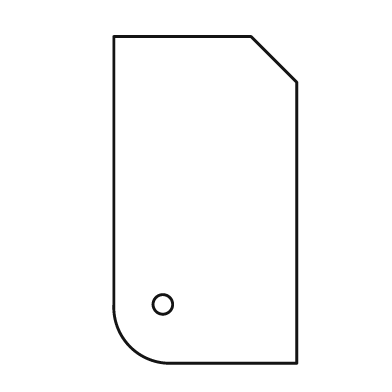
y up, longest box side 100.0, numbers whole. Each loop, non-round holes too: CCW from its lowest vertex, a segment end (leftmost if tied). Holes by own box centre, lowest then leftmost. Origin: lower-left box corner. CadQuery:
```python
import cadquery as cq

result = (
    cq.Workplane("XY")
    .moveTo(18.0, 0.0)
    .lineTo(56.0, 0.0)
    .lineTo(56.0, 86.0)
    .lineTo(42.0, 100.0)
    .lineTo(0.0, 100.0)
    .lineTo(0.0, 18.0)
    .threePointArc((5.0, 5.0), (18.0, 0.0))
    .close()
    .moveTo(15.0, 18.0)
    .circle(3.0)
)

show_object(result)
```